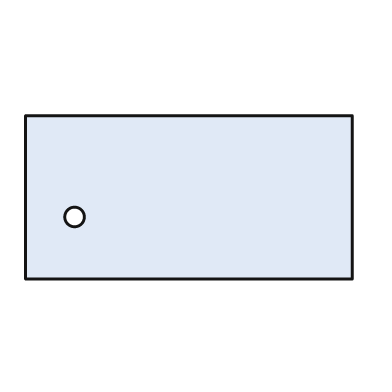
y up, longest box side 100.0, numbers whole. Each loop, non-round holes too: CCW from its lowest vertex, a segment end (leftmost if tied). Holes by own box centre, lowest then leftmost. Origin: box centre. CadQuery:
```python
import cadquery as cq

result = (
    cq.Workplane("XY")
    .moveTo(-50.0, -25.0)
    .lineTo(50.0, -25.0)
    .lineTo(50.0, 25.0)
    .lineTo(-50.0, 25.0)
    .close()
    .moveTo(-35.0, -6.0)
    .circle(3.0)
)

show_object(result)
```